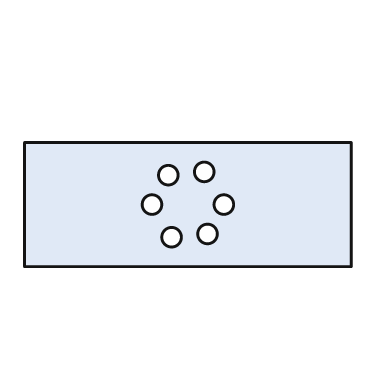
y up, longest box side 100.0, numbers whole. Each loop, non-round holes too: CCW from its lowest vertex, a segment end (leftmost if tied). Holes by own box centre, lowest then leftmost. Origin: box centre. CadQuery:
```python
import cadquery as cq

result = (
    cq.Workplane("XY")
    .moveTo(-50.0, -19.0)
    .lineTo(50.0, -19.0)
    .lineTo(50.0, 19.0)
    .lineTo(-50.0, 19.0)
    .close()
    .moveTo(-5.0, -10.0)
    .circle(3.0)
    .moveTo(6.0, -9.0)
    .circle(3.0)
    .moveTo(-11.0, 0.0)
    .circle(3.0)
    .moveTo(11.0, 0.0)
    .circle(3.0)
    .moveTo(-6.0, 9.0)
    .circle(3.0)
    .moveTo(5.0, 10.0)
    .circle(3.0)
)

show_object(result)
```